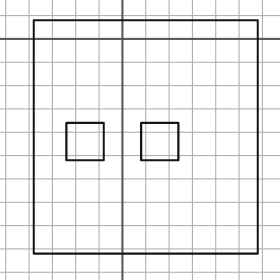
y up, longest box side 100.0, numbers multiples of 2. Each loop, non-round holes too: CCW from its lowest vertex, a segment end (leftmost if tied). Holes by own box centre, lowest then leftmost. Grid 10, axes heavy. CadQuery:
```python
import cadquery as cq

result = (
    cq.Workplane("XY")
    .moveTo(-38.0, -92.0)
    .lineTo(58.0, -92.0)
    .lineTo(58.0, 8.0)
    .lineTo(-38.0, 8.0)
    .close()
    .moveTo(-24.0, -52.0)
    .lineTo(-8.0, -52.0)
    .lineTo(-8.0, -36.0)
    .lineTo(-24.0, -36.0)
    .close()
    .moveTo(8.0, -52.0)
    .lineTo(24.0, -52.0)
    .lineTo(24.0, -36.0)
    .lineTo(8.0, -36.0)
    .close()
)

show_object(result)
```